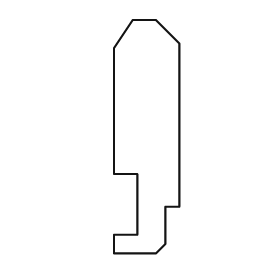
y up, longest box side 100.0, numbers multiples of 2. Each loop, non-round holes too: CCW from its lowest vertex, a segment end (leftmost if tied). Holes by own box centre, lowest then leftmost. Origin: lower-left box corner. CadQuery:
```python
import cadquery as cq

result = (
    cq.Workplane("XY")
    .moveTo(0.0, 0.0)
    .lineTo(18.0, 0.0)
    .lineTo(22.0, 4.0)
    .lineTo(22.0, 20.0)
    .lineTo(28.0, 20.0)
    .lineTo(28.0, 90.0)
    .lineTo(18.0, 100.0)
    .lineTo(8.0, 100.0)
    .lineTo(0.0, 88.0)
    .lineTo(0.0, 34.0)
    .lineTo(10.0, 34.0)
    .lineTo(10.0, 8.0)
    .lineTo(0.0, 8.0)
    .close()
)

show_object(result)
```